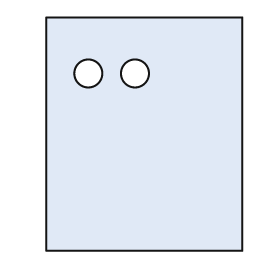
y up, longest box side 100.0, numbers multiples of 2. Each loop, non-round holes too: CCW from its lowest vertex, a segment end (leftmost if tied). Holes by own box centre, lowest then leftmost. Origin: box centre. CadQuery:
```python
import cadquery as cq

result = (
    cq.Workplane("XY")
    .moveTo(-42.0, -50.0)
    .lineTo(42.0, -50.0)
    .lineTo(42.0, 50.0)
    .lineTo(-42.0, 50.0)
    .close()
    .moveTo(-24.0, 26.0)
    .circle(6.0)
    .moveTo(-4.0, 26.0)
    .circle(6.0)
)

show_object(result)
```